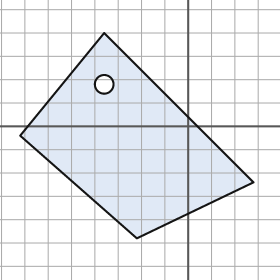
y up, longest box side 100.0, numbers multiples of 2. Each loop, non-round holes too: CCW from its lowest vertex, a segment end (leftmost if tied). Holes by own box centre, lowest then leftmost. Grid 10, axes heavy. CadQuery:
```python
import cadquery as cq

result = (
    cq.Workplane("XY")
    .moveTo(-22.0, -48.0)
    .lineTo(28.0, -24.0)
    .lineTo(-36.0, 40.0)
    .lineTo(-72.0, -4.0)
    .close()
    .moveTo(-36.0, 18.0)
    .circle(4.0)
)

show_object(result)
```